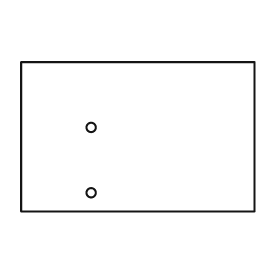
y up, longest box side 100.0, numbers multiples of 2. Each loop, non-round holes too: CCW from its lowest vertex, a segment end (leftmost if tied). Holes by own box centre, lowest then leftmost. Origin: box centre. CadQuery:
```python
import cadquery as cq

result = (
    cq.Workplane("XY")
    .moveTo(-50.0, -32.0)
    .lineTo(50.0, -32.0)
    .lineTo(50.0, 32.0)
    .lineTo(-50.0, 32.0)
    .close()
    .moveTo(-20.0, -24.0)
    .circle(2.0)
    .moveTo(-20.0, 4.0)
    .circle(2.0)
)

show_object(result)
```